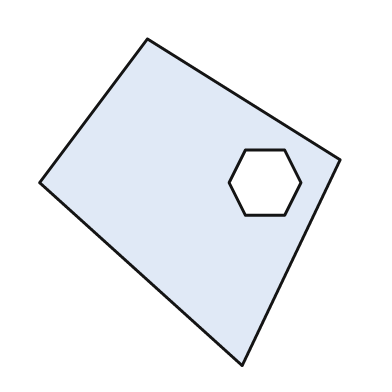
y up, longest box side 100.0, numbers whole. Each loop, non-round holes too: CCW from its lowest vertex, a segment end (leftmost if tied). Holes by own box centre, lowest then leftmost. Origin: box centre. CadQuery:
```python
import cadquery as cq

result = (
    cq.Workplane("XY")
    .moveTo(16.0, -50.0)
    .lineTo(46.0, 13.0)
    .lineTo(-13.0, 50.0)
    .lineTo(-46.0, 6.0)
    .close()
    .moveTo(17.0, -4.0)
    .lineTo(29.0, -4.0)
    .lineTo(34.0, 6.0)
    .lineTo(29.0, 16.0)
    .lineTo(17.0, 16.0)
    .lineTo(12.0, 6.0)
    .close()
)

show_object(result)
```